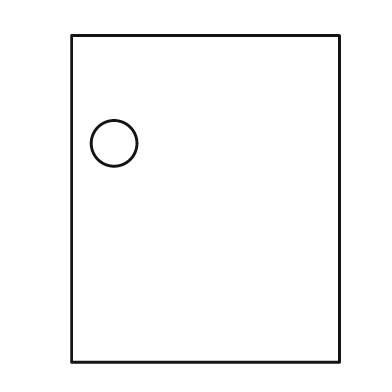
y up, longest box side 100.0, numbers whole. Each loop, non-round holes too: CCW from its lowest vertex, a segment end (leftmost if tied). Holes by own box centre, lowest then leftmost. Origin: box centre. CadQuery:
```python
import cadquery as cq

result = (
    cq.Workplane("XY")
    .moveTo(-41.0, -50.0)
    .lineTo(41.0, -50.0)
    .lineTo(41.0, 50.0)
    .lineTo(-41.0, 50.0)
    .close()
    .moveTo(-28.0, 17.0)
    .circle(7.0)
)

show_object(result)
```